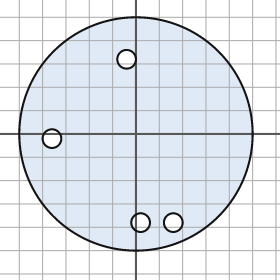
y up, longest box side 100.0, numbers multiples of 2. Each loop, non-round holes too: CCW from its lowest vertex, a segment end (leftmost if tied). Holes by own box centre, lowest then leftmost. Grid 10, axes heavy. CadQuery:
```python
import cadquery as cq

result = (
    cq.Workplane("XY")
    .moveTo(0.0, 0.0)
    .circle(50.0)
    .moveTo(2.0, -38.0)
    .circle(4.0)
    .moveTo(16.0, -38.0)
    .circle(4.0)
    .moveTo(-36.0, -2.0)
    .circle(4.0)
    .moveTo(-4.0, 32.0)
    .circle(4.0)
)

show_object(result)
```